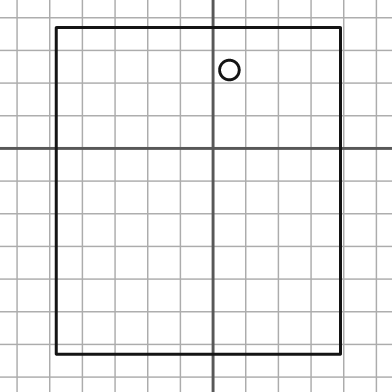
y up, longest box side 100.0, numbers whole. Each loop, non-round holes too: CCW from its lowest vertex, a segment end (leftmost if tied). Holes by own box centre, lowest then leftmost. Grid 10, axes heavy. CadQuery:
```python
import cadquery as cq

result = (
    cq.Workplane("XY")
    .moveTo(-48.0, -63.0)
    .lineTo(39.0, -63.0)
    .lineTo(39.0, 37.0)
    .lineTo(-48.0, 37.0)
    .close()
    .moveTo(5.0, 24.0)
    .circle(3.0)
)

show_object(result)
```